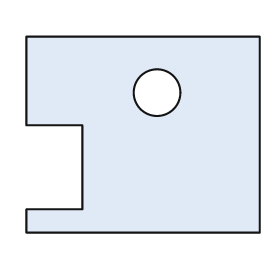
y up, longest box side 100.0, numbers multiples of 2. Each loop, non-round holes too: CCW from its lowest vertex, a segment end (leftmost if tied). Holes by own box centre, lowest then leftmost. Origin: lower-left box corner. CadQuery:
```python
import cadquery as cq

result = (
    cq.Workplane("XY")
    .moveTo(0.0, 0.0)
    .lineTo(100.0, 0.0)
    .lineTo(100.0, 84.0)
    .lineTo(0.0, 84.0)
    .lineTo(0.0, 46.0)
    .lineTo(24.0, 46.0)
    .lineTo(24.0, 10.0)
    .lineTo(0.0, 10.0)
    .close()
    .moveTo(56.0, 60.0)
    .circle(10.0)
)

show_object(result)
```